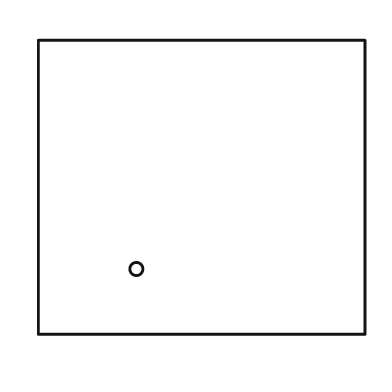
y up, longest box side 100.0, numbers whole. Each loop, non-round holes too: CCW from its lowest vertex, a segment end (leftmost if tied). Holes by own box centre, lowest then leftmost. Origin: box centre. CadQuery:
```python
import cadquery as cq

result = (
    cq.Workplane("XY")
    .moveTo(-50.0, -45.0)
    .lineTo(50.0, -45.0)
    .lineTo(50.0, 45.0)
    .lineTo(-50.0, 45.0)
    .close()
    .moveTo(-20.0, -25.0)
    .circle(2.0)
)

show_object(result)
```